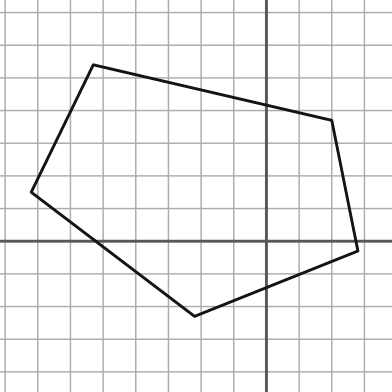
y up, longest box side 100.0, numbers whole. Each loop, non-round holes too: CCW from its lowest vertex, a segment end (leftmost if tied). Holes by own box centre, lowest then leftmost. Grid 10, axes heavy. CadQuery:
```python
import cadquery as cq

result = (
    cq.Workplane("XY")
    .moveTo(-22.0, -23.0)
    .lineTo(28.0, -3.0)
    .lineTo(20.0, 37.0)
    .lineTo(-53.0, 54.0)
    .lineTo(-72.0, 15.0)
    .close()
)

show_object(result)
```